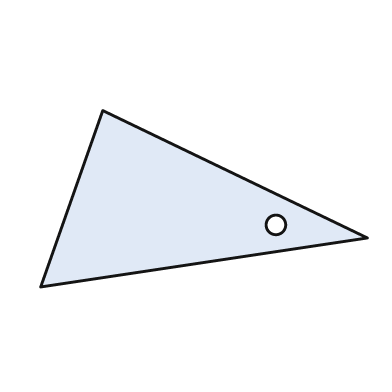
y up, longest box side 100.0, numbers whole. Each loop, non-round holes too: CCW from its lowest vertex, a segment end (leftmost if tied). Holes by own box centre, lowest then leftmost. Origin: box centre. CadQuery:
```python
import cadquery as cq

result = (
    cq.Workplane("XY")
    .moveTo(-50.0, -27.0)
    .lineTo(50.0, -12.0)
    .lineTo(-31.0, 27.0)
    .close()
    .moveTo(22.0, -8.0)
    .circle(3.0)
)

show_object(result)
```